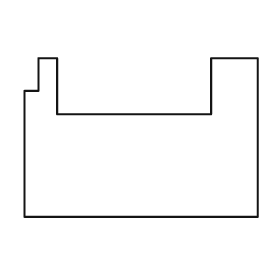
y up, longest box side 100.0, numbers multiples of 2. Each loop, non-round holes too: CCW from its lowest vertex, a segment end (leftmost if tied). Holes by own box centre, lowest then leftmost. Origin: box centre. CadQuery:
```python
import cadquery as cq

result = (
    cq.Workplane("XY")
    .moveTo(-50.0, -34.0)
    .lineTo(50.0, -34.0)
    .lineTo(50.0, 34.0)
    .lineTo(30.0, 34.0)
    .lineTo(30.0, 10.0)
    .lineTo(-36.0, 10.0)
    .lineTo(-36.0, 34.0)
    .lineTo(-44.0, 34.0)
    .lineTo(-44.0, 20.0)
    .lineTo(-50.0, 20.0)
    .close()
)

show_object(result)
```